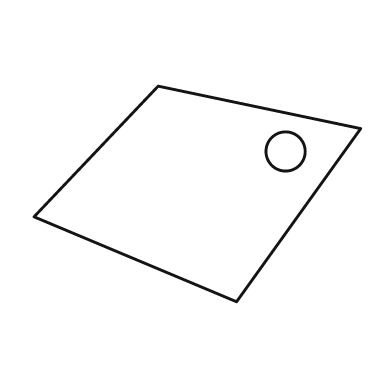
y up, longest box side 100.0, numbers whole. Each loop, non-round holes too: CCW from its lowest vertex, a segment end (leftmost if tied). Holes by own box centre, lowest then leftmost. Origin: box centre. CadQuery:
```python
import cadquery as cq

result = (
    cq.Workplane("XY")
    .moveTo(12.0, -33.0)
    .lineTo(50.0, 20.0)
    .lineTo(-12.0, 33.0)
    .lineTo(-50.0, -7.0)
    .close()
    .moveTo(27.0, 13.0)
    .circle(6.0)
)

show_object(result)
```